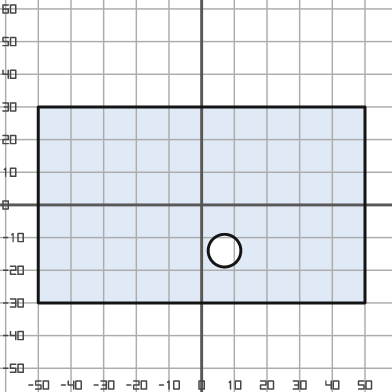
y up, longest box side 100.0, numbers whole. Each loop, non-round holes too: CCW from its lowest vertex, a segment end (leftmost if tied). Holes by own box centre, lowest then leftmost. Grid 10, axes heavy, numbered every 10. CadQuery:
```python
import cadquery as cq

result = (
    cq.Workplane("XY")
    .moveTo(-50.0, -30.0)
    .lineTo(50.0, -30.0)
    .lineTo(50.0, 30.0)
    .lineTo(-50.0, 30.0)
    .close()
    .moveTo(7.0, -14.0)
    .circle(5.0)
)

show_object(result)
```